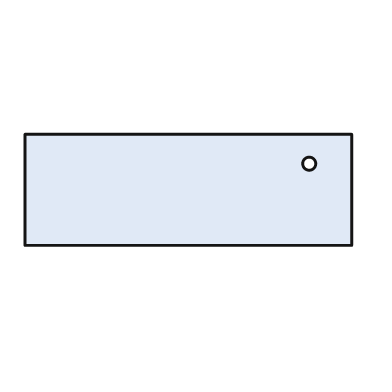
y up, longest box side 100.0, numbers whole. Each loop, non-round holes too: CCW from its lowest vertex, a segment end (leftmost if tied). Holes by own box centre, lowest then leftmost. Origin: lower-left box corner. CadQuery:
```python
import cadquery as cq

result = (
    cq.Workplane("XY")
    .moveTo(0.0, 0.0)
    .lineTo(100.0, 0.0)
    .lineTo(100.0, 34.0)
    .lineTo(0.0, 34.0)
    .close()
    .moveTo(87.0, 25.0)
    .circle(2.0)
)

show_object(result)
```